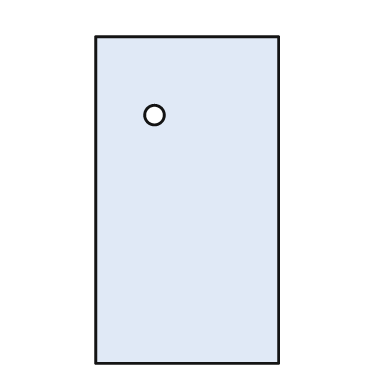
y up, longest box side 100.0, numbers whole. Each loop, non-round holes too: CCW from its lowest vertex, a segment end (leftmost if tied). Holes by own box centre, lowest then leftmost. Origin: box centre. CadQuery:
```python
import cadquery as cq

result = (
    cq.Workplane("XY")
    .moveTo(-28.0, -50.0)
    .lineTo(28.0, -50.0)
    .lineTo(28.0, 50.0)
    .lineTo(-28.0, 50.0)
    .close()
    .moveTo(-10.0, 26.0)
    .circle(3.0)
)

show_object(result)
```